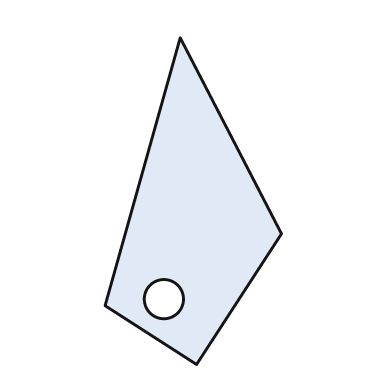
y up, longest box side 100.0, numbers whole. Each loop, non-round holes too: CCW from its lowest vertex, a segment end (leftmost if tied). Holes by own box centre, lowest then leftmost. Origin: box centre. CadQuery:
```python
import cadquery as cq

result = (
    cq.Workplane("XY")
    .moveTo(1.0, -50.0)
    .lineTo(27.0, -10.0)
    .lineTo(-4.0, 50.0)
    .lineTo(-27.0, -32.0)
    .close()
    .moveTo(-9.0, -30.0)
    .circle(6.0)
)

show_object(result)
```